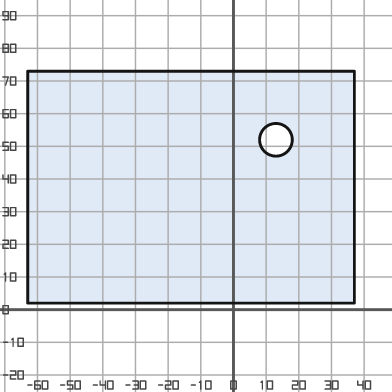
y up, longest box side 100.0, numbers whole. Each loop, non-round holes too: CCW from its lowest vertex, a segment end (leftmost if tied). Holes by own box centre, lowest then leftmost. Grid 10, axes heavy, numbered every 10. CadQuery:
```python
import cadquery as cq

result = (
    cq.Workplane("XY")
    .moveTo(-63.0, 2.0)
    .lineTo(37.0, 2.0)
    .lineTo(37.0, 73.0)
    .lineTo(-63.0, 73.0)
    .close()
    .moveTo(13.0, 52.0)
    .circle(5.0)
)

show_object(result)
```